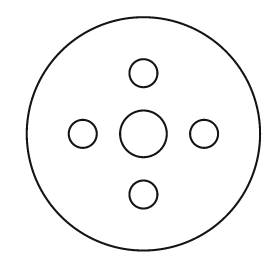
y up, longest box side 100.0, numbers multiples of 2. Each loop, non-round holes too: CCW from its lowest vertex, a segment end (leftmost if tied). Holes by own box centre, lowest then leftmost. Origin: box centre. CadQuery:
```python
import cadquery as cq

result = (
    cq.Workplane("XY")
    .moveTo(0.0, 0.0)
    .circle(50.0)
    .moveTo(0.0, -26.0)
    .circle(6.0)
    .moveTo(-26.0, 0.0)
    .circle(6.0)
    .moveTo(0.0, 0.0)
    .circle(10.0)
    .moveTo(26.0, 0.0)
    .circle(6.0)
    .moveTo(0.0, 26.0)
    .circle(6.0)
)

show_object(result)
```